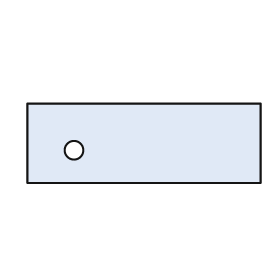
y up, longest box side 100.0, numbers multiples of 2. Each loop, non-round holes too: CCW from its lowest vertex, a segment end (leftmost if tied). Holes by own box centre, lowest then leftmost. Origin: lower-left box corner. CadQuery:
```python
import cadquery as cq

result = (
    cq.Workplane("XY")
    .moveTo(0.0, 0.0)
    .lineTo(100.0, 0.0)
    .lineTo(100.0, 34.0)
    .lineTo(0.0, 34.0)
    .close()
    .moveTo(20.0, 14.0)
    .circle(4.0)
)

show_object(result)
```